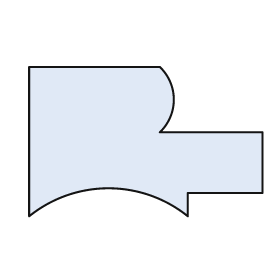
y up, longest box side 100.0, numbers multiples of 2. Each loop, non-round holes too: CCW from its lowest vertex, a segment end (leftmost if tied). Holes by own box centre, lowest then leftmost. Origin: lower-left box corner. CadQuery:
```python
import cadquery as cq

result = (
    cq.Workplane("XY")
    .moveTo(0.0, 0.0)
    .threePointArc((34.0, 12.0), (68.0, 0.0))
    .lineTo(68.0, 10.0)
    .lineTo(100.0, 10.0)
    .lineTo(100.0, 36.0)
    .lineTo(56.0, 36.0)
    .threePointArc((62.0, 50.0), (56.0, 64.0))
    .lineTo(0.0, 64.0)
    .close()
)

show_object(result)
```